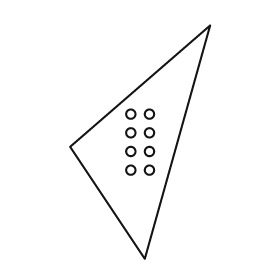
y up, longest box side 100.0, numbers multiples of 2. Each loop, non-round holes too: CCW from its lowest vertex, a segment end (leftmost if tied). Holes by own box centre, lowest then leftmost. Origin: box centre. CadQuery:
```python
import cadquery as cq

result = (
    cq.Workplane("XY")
    .moveTo(2.0, -50.0)
    .lineTo(30.0, 50.0)
    .lineTo(-30.0, -2.0)
    .close()
    .moveTo(-4.0, -12.0)
    .circle(2.0)
    .moveTo(4.0, -12.0)
    .circle(2.0)
    .moveTo(-4.0, -4.0)
    .circle(2.0)
    .moveTo(4.0, -4.0)
    .circle(2.0)
    .moveTo(-4.0, 4.0)
    .circle(2.0)
    .moveTo(4.0, 4.0)
    .circle(2.0)
    .moveTo(-4.0, 12.0)
    .circle(2.0)
    .moveTo(4.0, 12.0)
    .circle(2.0)
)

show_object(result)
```